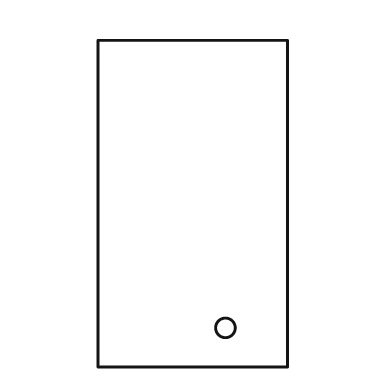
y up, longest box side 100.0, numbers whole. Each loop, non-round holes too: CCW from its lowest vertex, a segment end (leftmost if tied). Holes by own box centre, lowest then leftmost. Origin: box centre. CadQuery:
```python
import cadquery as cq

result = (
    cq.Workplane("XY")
    .moveTo(-29.0, -50.0)
    .lineTo(29.0, -50.0)
    .lineTo(29.0, 50.0)
    .lineTo(-29.0, 50.0)
    .close()
    .moveTo(10.0, -38.0)
    .circle(3.0)
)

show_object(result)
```